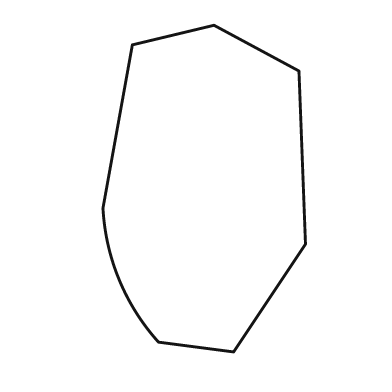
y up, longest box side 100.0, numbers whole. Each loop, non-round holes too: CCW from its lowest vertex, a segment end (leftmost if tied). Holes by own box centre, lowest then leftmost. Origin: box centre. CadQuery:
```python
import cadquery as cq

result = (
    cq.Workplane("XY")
    .moveTo(9.0, -50.0)
    .lineTo(31.0, -17.0)
    .lineTo(29.0, 36.0)
    .lineTo(3.0, 50.0)
    .lineTo(-22.0, 44.0)
    .lineTo(-31.0, -6.0)
    .threePointArc((-26.0, -28.0), (-14.0, -47.0))
    .close()
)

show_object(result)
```